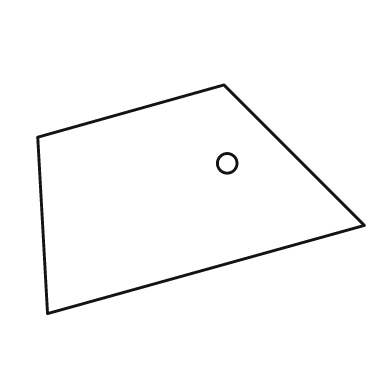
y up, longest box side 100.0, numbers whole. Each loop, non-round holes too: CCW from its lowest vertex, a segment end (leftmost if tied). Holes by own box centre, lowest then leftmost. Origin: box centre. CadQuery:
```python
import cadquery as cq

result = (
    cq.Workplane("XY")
    .moveTo(-47.0, -35.0)
    .lineTo(50.0, -8.0)
    .lineTo(7.0, 35.0)
    .lineTo(-50.0, 19.0)
    .close()
    .moveTo(8.0, 11.0)
    .circle(3.0)
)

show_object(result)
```